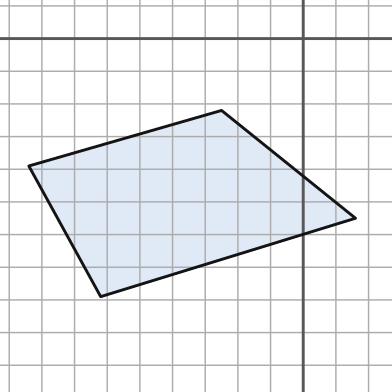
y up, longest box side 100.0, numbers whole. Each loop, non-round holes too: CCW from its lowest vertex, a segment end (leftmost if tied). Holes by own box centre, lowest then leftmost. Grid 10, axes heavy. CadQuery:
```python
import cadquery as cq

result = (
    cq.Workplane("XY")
    .moveTo(-62.0, -79.0)
    .lineTo(16.0, -55.0)
    .lineTo(-25.0, -22.0)
    .lineTo(-84.0, -39.0)
    .close()
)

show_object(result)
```